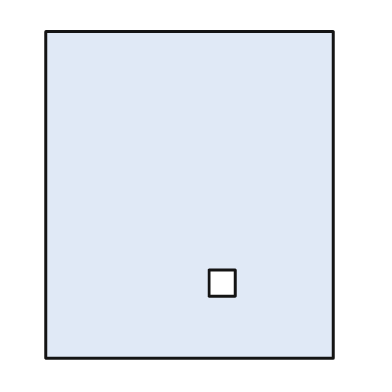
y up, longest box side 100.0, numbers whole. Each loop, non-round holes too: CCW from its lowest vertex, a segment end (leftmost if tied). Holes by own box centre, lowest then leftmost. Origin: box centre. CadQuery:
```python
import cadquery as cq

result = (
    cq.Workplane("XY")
    .moveTo(-44.0, -50.0)
    .lineTo(44.0, -50.0)
    .lineTo(44.0, 50.0)
    .lineTo(-44.0, 50.0)
    .close()
    .moveTo(6.0, -31.0)
    .lineTo(14.0, -31.0)
    .lineTo(14.0, -23.0)
    .lineTo(6.0, -23.0)
    .close()
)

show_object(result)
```